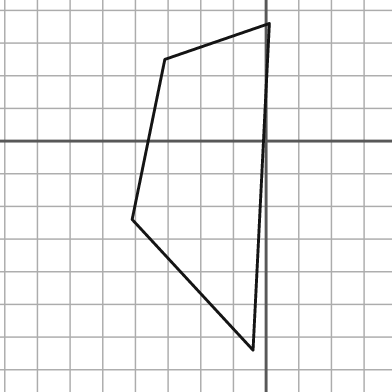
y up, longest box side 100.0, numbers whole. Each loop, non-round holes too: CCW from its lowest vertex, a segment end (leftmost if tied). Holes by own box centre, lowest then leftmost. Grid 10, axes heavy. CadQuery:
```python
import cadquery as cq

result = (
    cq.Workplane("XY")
    .moveTo(-4.0, -64.0)
    .lineTo(1.0, 36.0)
    .lineTo(-31.0, 25.0)
    .lineTo(-41.0, -24.0)
    .close()
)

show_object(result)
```